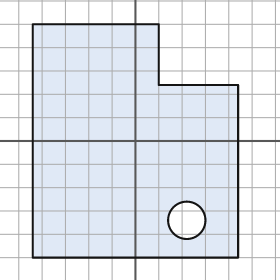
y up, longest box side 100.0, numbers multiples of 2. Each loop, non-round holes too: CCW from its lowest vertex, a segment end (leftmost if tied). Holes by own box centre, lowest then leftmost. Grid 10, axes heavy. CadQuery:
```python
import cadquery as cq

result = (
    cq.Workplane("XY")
    .moveTo(-44.0, -50.0)
    .lineTo(44.0, -50.0)
    .lineTo(44.0, 24.0)
    .lineTo(10.0, 24.0)
    .lineTo(10.0, 50.0)
    .lineTo(-44.0, 50.0)
    .close()
    .moveTo(22.0, -34.0)
    .circle(8.0)
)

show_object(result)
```